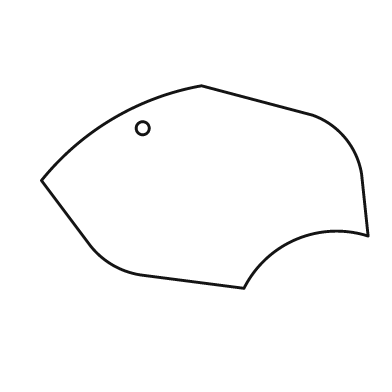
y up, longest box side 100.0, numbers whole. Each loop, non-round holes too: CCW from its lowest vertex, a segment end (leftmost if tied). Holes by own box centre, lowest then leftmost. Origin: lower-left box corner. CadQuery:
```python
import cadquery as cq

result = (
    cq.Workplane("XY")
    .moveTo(62.0, 0.0)
    .threePointArc((78.0, 15.0), (100.0, 16.0))
    .lineTo(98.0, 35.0)
    .threePointArc((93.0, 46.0), (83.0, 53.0))
    .lineTo(49.0, 62.0)
    .threePointArc((22.0, 52.0), (0.0, 33.0))
    .lineTo(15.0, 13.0)
    .threePointArc((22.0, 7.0), (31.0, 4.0))
    .close()
    .moveTo(31.0, 49.0)
    .circle(2.0)
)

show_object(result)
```